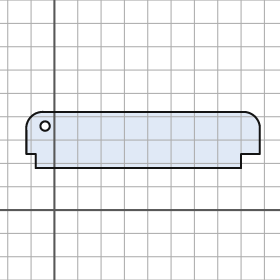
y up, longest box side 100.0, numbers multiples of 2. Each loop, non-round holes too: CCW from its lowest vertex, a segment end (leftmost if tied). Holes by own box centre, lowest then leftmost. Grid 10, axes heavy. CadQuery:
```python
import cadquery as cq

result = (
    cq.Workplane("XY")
    .moveTo(-8.0, 18.0)
    .lineTo(80.0, 18.0)
    .lineTo(80.0, 24.0)
    .lineTo(88.0, 24.0)
    .lineTo(88.0, 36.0)
    .threePointArc((86.0, 40.0), (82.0, 42.0))
    .lineTo(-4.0, 42.0)
    .threePointArc((-10.0, 40.0), (-12.0, 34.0))
    .lineTo(-12.0, 24.0)
    .lineTo(-8.0, 24.0)
    .close()
    .moveTo(-4.0, 36.0)
    .circle(2.0)
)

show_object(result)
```